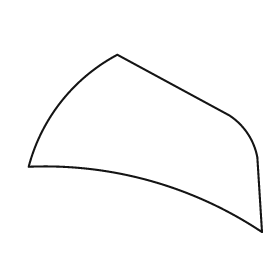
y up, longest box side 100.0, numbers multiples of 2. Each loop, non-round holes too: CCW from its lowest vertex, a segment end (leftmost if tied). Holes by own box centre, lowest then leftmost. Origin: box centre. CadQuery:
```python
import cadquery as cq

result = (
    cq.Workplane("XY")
    .moveTo(50.0, -38.0)
    .lineTo(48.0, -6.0)
    .threePointArc((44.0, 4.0), (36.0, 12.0))
    .lineTo(-12.0, 38.0)
    .threePointArc((-36.0, 18.0), (-50.0, -10.0))
    .threePointArc((2.0, -16.0), (50.0, -38.0))
    .close()
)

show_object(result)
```